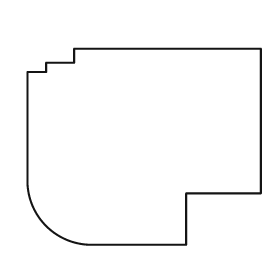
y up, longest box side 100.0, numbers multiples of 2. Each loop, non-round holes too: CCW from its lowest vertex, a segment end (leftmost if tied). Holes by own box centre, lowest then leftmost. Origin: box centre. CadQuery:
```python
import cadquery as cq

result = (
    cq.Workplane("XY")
    .moveTo(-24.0, -42.0)
    .lineTo(18.0, -42.0)
    .lineTo(18.0, -20.0)
    .lineTo(50.0, -20.0)
    .lineTo(50.0, 42.0)
    .lineTo(-30.0, 42.0)
    .lineTo(-30.0, 36.0)
    .lineTo(-42.0, 36.0)
    .lineTo(-42.0, 32.0)
    .lineTo(-50.0, 32.0)
    .lineTo(-50.0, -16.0)
    .threePointArc((-42.0, -34.0), (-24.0, -42.0))
    .close()
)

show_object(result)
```